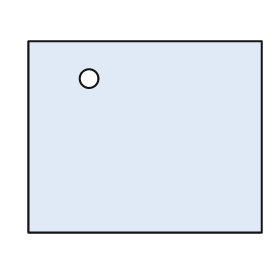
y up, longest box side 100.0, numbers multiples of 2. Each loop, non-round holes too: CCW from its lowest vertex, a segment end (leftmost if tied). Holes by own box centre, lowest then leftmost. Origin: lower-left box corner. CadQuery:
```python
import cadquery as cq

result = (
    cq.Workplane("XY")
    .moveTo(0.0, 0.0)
    .lineTo(100.0, 0.0)
    .lineTo(100.0, 82.0)
    .lineTo(0.0, 82.0)
    .close()
    .moveTo(26.0, 66.0)
    .circle(4.0)
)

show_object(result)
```